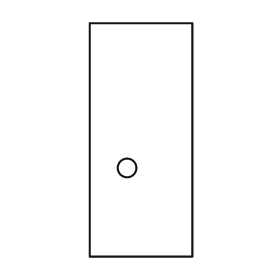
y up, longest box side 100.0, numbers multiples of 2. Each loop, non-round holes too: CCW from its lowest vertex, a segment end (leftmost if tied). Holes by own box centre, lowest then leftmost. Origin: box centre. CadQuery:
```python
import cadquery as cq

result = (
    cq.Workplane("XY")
    .moveTo(-22.0, -50.0)
    .lineTo(22.0, -50.0)
    .lineTo(22.0, 50.0)
    .lineTo(-22.0, 50.0)
    .close()
    .moveTo(-6.0, -12.0)
    .circle(4.0)
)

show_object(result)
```